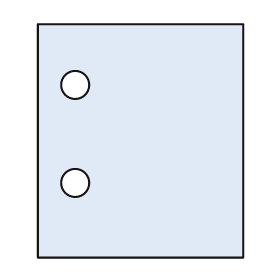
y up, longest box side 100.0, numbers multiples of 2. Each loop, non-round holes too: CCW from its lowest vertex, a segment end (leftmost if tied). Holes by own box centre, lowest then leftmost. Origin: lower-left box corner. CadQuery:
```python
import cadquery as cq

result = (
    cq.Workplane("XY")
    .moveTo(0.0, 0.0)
    .lineTo(88.0, 0.0)
    .lineTo(88.0, 100.0)
    .lineTo(0.0, 100.0)
    .close()
    .moveTo(16.0, 32.0)
    .circle(6.0)
    .moveTo(16.0, 74.0)
    .circle(6.0)
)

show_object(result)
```